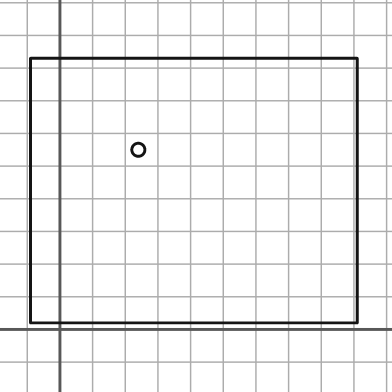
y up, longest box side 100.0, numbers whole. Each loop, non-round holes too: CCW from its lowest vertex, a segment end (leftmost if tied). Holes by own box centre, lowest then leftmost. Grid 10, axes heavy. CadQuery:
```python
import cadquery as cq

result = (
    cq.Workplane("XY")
    .moveTo(-9.0, 2.0)
    .lineTo(91.0, 2.0)
    .lineTo(91.0, 83.0)
    .lineTo(-9.0, 83.0)
    .close()
    .moveTo(24.0, 55.0)
    .circle(2.0)
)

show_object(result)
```